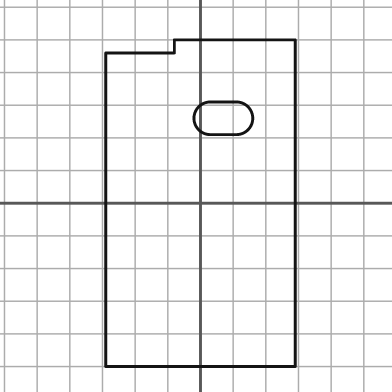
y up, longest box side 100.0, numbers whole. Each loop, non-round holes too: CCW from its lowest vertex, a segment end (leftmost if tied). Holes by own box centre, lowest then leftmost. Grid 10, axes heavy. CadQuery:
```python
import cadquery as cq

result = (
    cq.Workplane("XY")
    .moveTo(-29.0, -50.0)
    .lineTo(29.0, -50.0)
    .lineTo(29.0, 50.0)
    .lineTo(-8.0, 50.0)
    .lineTo(-8.0, 46.0)
    .lineTo(-29.0, 46.0)
    .close()
    .moveTo(3.0, 21.0)
    .lineTo(11.0, 21.0)
    .threePointArc((16.0, 26.0), (11.0, 31.0))
    .lineTo(3.0, 31.0)
    .threePointArc((-2.0, 26.0), (3.0, 21.0))
    .close()
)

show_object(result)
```